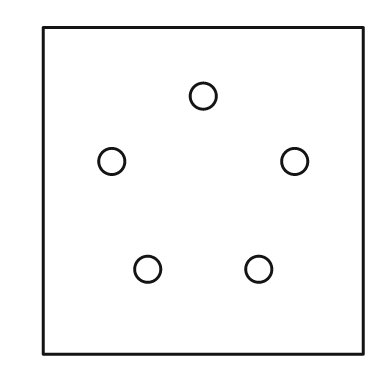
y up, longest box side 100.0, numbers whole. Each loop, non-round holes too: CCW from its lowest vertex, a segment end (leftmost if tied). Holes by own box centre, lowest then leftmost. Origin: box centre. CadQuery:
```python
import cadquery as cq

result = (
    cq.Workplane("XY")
    .moveTo(-49.0, -50.0)
    .lineTo(49.0, -50.0)
    .lineTo(49.0, 50.0)
    .lineTo(-49.0, 50.0)
    .close()
    .moveTo(-17.0, -24.0)
    .circle(4.0)
    .moveTo(17.0, -24.0)
    .circle(4.0)
    .moveTo(-28.0, 9.0)
    .circle(4.0)
    .moveTo(28.0, 9.0)
    .circle(4.0)
    .moveTo(0.0, 29.0)
    .circle(4.0)
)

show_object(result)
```